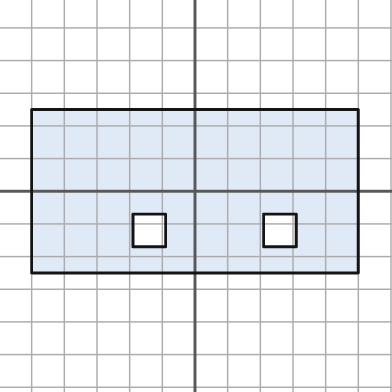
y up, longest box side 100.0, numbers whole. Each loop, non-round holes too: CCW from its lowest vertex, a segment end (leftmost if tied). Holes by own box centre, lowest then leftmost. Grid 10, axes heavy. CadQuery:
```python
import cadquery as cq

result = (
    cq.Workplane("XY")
    .moveTo(-50.0, -25.0)
    .lineTo(50.0, -25.0)
    .lineTo(50.0, 25.0)
    .lineTo(-50.0, 25.0)
    .close()
    .moveTo(-19.0, -17.0)
    .lineTo(-9.0, -17.0)
    .lineTo(-9.0, -7.0)
    .lineTo(-19.0, -7.0)
    .close()
    .moveTo(21.0, -17.0)
    .lineTo(31.0, -17.0)
    .lineTo(31.0, -7.0)
    .lineTo(21.0, -7.0)
    .close()
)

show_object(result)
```